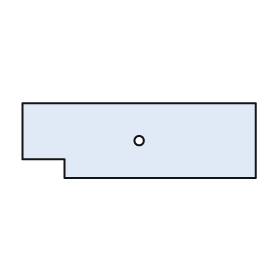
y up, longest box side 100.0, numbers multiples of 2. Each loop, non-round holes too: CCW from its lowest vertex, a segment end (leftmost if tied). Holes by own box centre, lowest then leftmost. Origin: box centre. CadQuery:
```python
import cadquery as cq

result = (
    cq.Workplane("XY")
    .moveTo(-32.0, -16.0)
    .lineTo(50.0, -16.0)
    .lineTo(50.0, 16.0)
    .lineTo(-50.0, 16.0)
    .lineTo(-50.0, -8.0)
    .lineTo(-32.0, -8.0)
    .close()
    .moveTo(0.0, 0.0)
    .circle(2.0)
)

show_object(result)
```